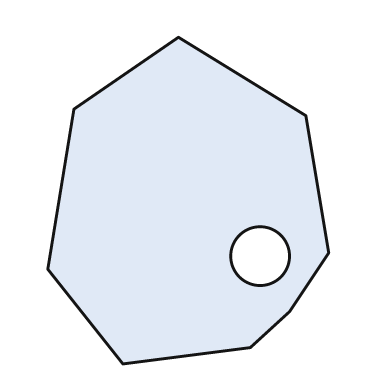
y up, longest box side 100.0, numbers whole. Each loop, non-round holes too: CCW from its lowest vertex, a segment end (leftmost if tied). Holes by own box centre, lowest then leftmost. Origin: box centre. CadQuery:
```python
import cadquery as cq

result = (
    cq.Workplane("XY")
    .moveTo(-20.0, -50.0)
    .lineTo(19.0, -45.0)
    .lineTo(31.0, -34.0)
    .lineTo(43.0, -16.0)
    .lineTo(36.0, 26.0)
    .lineTo(-3.0, 50.0)
    .lineTo(-35.0, 28.0)
    .lineTo(-43.0, -21.0)
    .close()
    .moveTo(22.0, -17.0)
    .circle(9.0)
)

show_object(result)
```